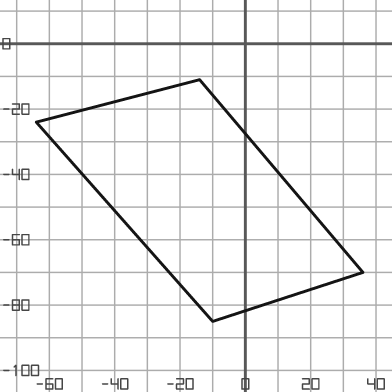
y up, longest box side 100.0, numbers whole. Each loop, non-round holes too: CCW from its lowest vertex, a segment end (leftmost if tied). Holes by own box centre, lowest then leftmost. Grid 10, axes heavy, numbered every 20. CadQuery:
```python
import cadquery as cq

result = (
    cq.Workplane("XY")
    .moveTo(-10.0, -85.0)
    .lineTo(36.0, -70.0)
    .lineTo(-14.0, -11.0)
    .lineTo(-64.0, -24.0)
    .close()
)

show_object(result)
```